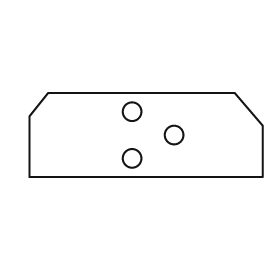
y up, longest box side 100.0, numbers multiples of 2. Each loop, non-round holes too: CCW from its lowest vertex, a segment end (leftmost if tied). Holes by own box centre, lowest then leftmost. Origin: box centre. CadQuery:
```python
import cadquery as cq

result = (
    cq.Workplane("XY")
    .moveTo(-50.0, -18.0)
    .lineTo(50.0, -18.0)
    .lineTo(50.0, 4.0)
    .lineTo(38.0, 18.0)
    .lineTo(-42.0, 18.0)
    .lineTo(-50.0, 8.0)
    .close()
    .moveTo(-6.0, -10.0)
    .circle(4.0)
    .moveTo(12.0, 0.0)
    .circle(4.0)
    .moveTo(-6.0, 10.0)
    .circle(4.0)
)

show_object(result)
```